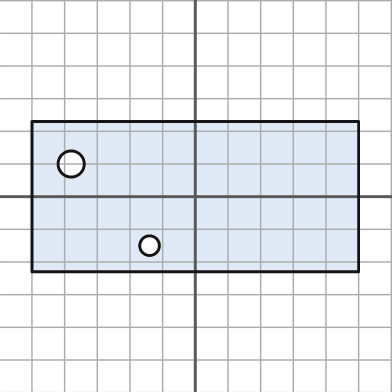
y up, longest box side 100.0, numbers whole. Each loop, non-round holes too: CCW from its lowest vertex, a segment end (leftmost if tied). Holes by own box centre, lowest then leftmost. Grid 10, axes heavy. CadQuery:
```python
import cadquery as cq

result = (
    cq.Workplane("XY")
    .moveTo(-50.0, -23.0)
    .lineTo(50.0, -23.0)
    .lineTo(50.0, 23.0)
    .lineTo(-50.0, 23.0)
    .close()
    .moveTo(-14.0, -15.0)
    .circle(3.0)
    .moveTo(-38.0, 10.0)
    .circle(4.0)
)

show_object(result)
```